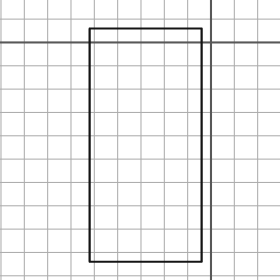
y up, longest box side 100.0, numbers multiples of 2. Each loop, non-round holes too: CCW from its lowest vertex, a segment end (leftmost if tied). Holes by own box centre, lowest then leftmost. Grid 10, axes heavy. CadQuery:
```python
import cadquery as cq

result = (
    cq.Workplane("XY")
    .moveTo(-52.0, -94.0)
    .lineTo(-4.0, -94.0)
    .lineTo(-4.0, 6.0)
    .lineTo(-52.0, 6.0)
    .close()
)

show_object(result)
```